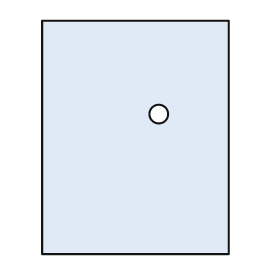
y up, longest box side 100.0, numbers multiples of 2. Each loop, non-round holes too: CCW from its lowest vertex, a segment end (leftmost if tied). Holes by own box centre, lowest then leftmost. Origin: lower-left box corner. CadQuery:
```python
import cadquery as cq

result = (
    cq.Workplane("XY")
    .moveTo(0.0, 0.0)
    .lineTo(80.0, 0.0)
    .lineTo(80.0, 100.0)
    .lineTo(0.0, 100.0)
    .close()
    .moveTo(50.0, 60.0)
    .circle(4.0)
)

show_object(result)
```